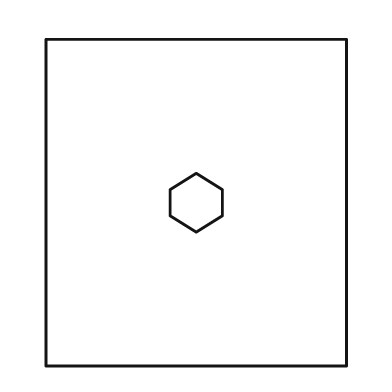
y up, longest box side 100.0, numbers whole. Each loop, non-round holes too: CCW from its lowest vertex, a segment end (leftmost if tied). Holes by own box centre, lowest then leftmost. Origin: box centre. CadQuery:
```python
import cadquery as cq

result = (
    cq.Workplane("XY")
    .moveTo(-46.0, -50.0)
    .lineTo(46.0, -50.0)
    .lineTo(46.0, 50.0)
    .lineTo(-46.0, 50.0)
    .close()
    .moveTo(0.0, -9.0)
    .lineTo(8.0, -4.0)
    .lineTo(8.0, 4.0)
    .lineTo(0.0, 9.0)
    .lineTo(-8.0, 4.0)
    .lineTo(-8.0, -4.0)
    .close()
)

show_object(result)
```